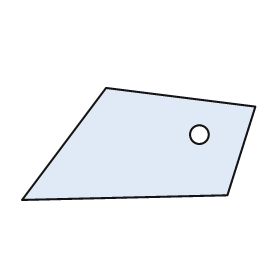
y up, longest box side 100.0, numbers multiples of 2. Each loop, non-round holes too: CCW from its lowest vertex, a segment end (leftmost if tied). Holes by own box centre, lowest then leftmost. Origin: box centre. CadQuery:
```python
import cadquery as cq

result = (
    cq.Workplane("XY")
    .moveTo(-50.0, -24.0)
    .lineTo(38.0, -22.0)
    .lineTo(50.0, 16.0)
    .lineTo(-14.0, 24.0)
    .close()
    .moveTo(26.0, 4.0)
    .circle(4.0)
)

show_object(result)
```